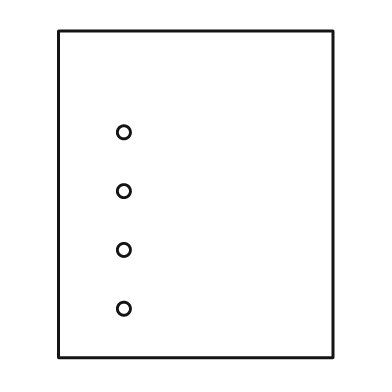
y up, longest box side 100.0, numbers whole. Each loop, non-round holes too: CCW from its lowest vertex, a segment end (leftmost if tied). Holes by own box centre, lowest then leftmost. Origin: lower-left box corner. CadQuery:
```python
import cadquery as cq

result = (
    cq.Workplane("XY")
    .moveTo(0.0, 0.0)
    .lineTo(84.0, 0.0)
    .lineTo(84.0, 100.0)
    .lineTo(0.0, 100.0)
    .close()
    .moveTo(20.0, 15.0)
    .circle(2.0)
    .moveTo(20.0, 33.0)
    .circle(2.0)
    .moveTo(20.0, 51.0)
    .circle(2.0)
    .moveTo(20.0, 69.0)
    .circle(2.0)
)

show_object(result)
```